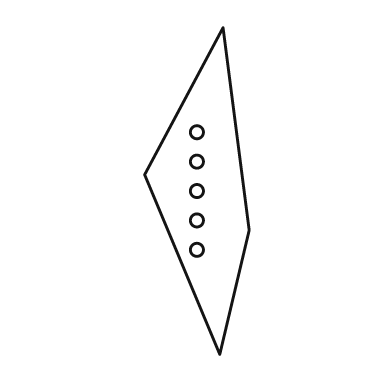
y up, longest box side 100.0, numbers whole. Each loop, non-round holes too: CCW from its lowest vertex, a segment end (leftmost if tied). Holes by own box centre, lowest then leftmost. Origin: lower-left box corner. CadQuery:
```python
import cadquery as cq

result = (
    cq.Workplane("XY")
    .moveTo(23.0, 0.0)
    .lineTo(32.0, 38.0)
    .lineTo(24.0, 100.0)
    .lineTo(0.0, 55.0)
    .close()
    .moveTo(16.0, 32.0)
    .circle(2.0)
    .moveTo(16.0, 41.0)
    .circle(2.0)
    .moveTo(16.0, 50.0)
    .circle(2.0)
    .moveTo(16.0, 59.0)
    .circle(2.0)
    .moveTo(16.0, 68.0)
    .circle(2.0)
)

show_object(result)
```